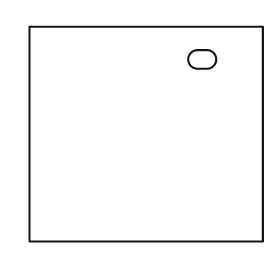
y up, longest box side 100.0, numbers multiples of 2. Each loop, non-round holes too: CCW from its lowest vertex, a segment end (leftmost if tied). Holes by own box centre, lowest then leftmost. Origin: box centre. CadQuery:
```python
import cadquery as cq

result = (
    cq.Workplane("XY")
    .moveTo(-50.0, -46.0)
    .lineTo(50.0, -46.0)
    .lineTo(50.0, 46.0)
    .lineTo(-50.0, 46.0)
    .close()
    .moveTo(22.0, 28.0)
    .lineTo(26.0, 28.0)
    .threePointArc((30.0, 32.0), (26.0, 36.0))
    .lineTo(22.0, 36.0)
    .threePointArc((18.0, 32.0), (22.0, 28.0))
    .close()
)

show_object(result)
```